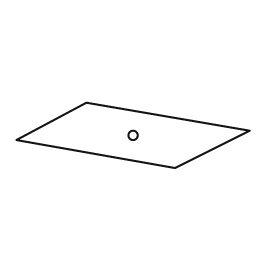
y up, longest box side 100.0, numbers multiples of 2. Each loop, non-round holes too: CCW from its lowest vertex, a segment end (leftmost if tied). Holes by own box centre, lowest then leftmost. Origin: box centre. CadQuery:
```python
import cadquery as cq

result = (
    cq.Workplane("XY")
    .moveTo(18.0, -14.0)
    .lineTo(50.0, 2.0)
    .lineTo(-20.0, 14.0)
    .lineTo(-50.0, -2.0)
    .close()
    .moveTo(0.0, 0.0)
    .circle(2.0)
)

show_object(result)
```